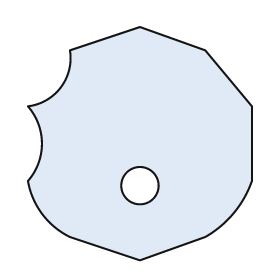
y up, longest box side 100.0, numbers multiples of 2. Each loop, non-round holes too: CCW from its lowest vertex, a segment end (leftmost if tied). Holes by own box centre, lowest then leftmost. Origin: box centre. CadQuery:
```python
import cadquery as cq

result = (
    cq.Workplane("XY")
    .moveTo(0.0, -50.0)
    .lineTo(28.0, -40.0)
    .threePointArc((40.0, -30.0), (48.0, -16.0))
    .lineTo(48.0, 16.0)
    .lineTo(28.0, 40.0)
    .lineTo(0.0, 50.0)
    .lineTo(-30.0, 40.0)
    .threePointArc((-34.0, 24.0), (-48.0, 16.0))
    .threePointArc((-42.0, 0.0), (-48.0, -16.0))
    .threePointArc((-42.0, -30.0), (-30.0, -40.0))
    .close()
    .moveTo(0.0, -18.0)
    .circle(8.0)
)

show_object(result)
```